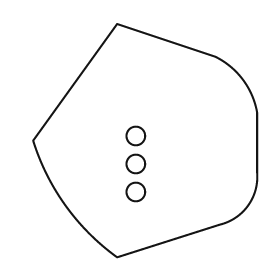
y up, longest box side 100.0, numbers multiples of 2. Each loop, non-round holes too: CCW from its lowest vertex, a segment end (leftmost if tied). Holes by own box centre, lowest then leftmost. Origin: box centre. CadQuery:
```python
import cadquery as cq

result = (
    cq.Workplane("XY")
    .moveTo(-12.0, -50.0)
    .lineTo(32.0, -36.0)
    .threePointArc((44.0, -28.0), (48.0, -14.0))
    .lineTo(48.0, 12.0)
    .threePointArc((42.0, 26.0), (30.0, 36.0))
    .lineTo(-12.0, 50.0)
    .lineTo(-48.0, 0.0)
    .threePointArc((-34.0, -28.0), (-12.0, -50.0))
    .close()
    .moveTo(-4.0, -22.0)
    .circle(4.0)
    .moveTo(-4.0, -10.0)
    .circle(4.0)
    .moveTo(-4.0, 2.0)
    .circle(4.0)
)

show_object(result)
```